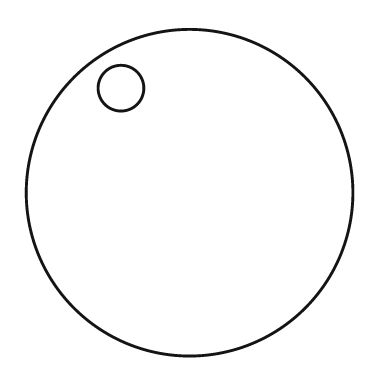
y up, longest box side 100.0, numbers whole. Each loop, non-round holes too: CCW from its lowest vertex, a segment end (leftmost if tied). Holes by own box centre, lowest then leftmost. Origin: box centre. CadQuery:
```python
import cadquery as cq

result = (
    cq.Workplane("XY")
    .moveTo(0.0, 0.0)
    .circle(50.0)
    .moveTo(-21.0, 32.0)
    .circle(7.0)
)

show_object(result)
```